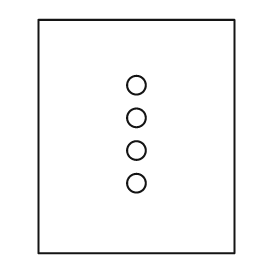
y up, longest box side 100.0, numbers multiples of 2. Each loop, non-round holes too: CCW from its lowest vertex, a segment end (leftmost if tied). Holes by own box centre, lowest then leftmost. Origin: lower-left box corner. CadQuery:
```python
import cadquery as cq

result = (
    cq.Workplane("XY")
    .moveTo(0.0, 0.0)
    .lineTo(84.0, 0.0)
    .lineTo(84.0, 100.0)
    .lineTo(0.0, 100.0)
    .close()
    .moveTo(42.0, 30.0)
    .circle(4.0)
    .moveTo(42.0, 44.0)
    .circle(4.0)
    .moveTo(42.0, 58.0)
    .circle(4.0)
    .moveTo(42.0, 72.0)
    .circle(4.0)
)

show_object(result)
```